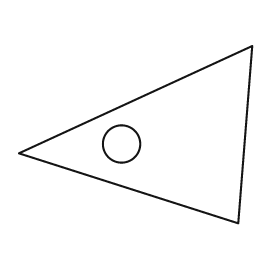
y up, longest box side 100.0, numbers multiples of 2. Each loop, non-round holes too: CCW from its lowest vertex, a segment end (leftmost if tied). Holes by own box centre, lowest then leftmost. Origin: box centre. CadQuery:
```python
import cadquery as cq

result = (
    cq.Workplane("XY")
    .moveTo(44.0, -38.0)
    .lineTo(50.0, 38.0)
    .lineTo(-50.0, -8.0)
    .close()
    .moveTo(-6.0, -4.0)
    .circle(8.0)
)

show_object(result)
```